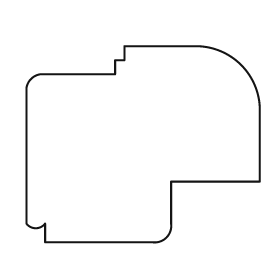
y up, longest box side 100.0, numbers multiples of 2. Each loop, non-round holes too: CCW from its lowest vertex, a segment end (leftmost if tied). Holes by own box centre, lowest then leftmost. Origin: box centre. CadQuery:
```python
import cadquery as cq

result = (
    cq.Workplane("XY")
    .moveTo(-42.0, -42.0)
    .lineTo(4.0, -42.0)
    .threePointArc((10.0, -40.0), (12.0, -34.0))
    .lineTo(12.0, -16.0)
    .lineTo(50.0, -16.0)
    .lineTo(50.0, 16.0)
    .threePointArc((42.0, 34.0), (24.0, 42.0))
    .lineTo(-8.0, 42.0)
    .lineTo(-8.0, 36.0)
    .lineTo(-12.0, 36.0)
    .lineTo(-12.0, 30.0)
    .lineTo(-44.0, 30.0)
    .threePointArc((-48.0, 28.0), (-50.0, 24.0))
    .lineTo(-50.0, -34.0)
    .threePointArc((-46.0, -36.0), (-42.0, -34.0))
    .close()
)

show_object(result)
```